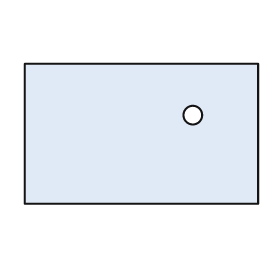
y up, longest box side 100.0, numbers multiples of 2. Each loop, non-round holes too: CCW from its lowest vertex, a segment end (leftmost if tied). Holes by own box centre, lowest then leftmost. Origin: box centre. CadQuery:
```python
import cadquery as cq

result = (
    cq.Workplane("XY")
    .moveTo(-50.0, -30.0)
    .lineTo(50.0, -30.0)
    .lineTo(50.0, 30.0)
    .lineTo(-50.0, 30.0)
    .close()
    .moveTo(22.0, 8.0)
    .circle(4.0)
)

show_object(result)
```